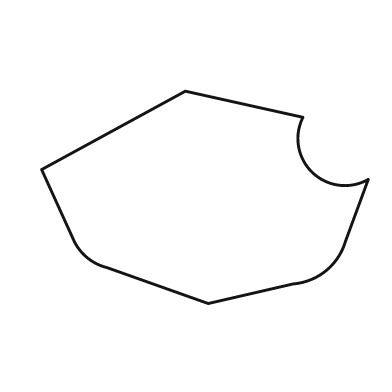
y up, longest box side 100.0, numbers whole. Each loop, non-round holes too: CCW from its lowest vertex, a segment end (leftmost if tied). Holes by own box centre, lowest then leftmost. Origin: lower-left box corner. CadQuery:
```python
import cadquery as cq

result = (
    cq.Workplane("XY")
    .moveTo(51.0, 0.0)
    .lineTo(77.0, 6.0)
    .threePointArc((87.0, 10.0), (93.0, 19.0))
    .lineTo(100.0, 38.0)
    .threePointArc((83.0, 40.0), (80.0, 57.0))
    .lineTo(44.0, 65.0)
    .lineTo(0.0, 41.0)
    .lineTo(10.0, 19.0)
    .threePointArc((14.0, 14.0), (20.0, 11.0))
    .close()
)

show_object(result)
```